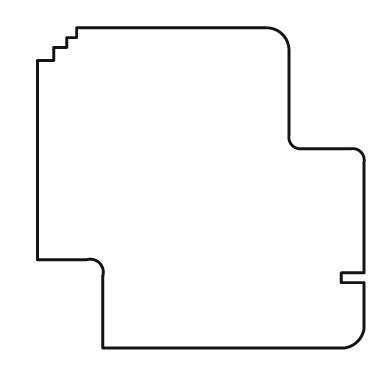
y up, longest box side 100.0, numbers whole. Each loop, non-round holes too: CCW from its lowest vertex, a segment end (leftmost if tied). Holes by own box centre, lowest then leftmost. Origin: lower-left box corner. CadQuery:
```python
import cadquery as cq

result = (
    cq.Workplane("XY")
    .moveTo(20.0, 0.0)
    .lineTo(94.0, 0.0)
    .threePointArc((98.0, 2.0), (100.0, 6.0))
    .lineTo(100.0, 20.0)
    .lineTo(93.0, 20.0)
    .lineTo(93.0, 23.0)
    .lineTo(100.0, 23.0)
    .lineTo(100.0, 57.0)
    .threePointArc((99.0, 60.0), (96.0, 61.0))
    .lineTo(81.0, 61.0)
    .threePointArc((78.0, 62.0), (77.0, 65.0))
    .lineTo(77.0, 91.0)
    .threePointArc((75.0, 96.0), (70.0, 98.0))
    .lineTo(12.0, 98.0)
    .lineTo(12.0, 95.0)
    .lineTo(9.0, 95.0)
    .lineTo(9.0, 92.0)
    .lineTo(5.0, 92.0)
    .lineTo(5.0, 88.0)
    .lineTo(0.0, 88.0)
    .lineTo(0.0, 27.0)
    .lineTo(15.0, 27.0)
    .threePointArc((19.0, 26.0), (20.0, 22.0))
    .close()
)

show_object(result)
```